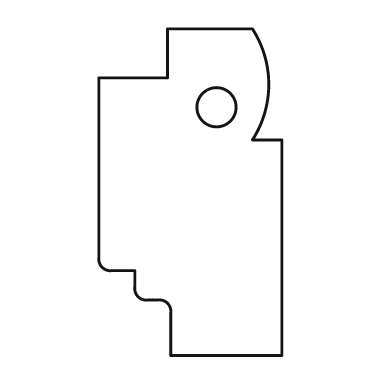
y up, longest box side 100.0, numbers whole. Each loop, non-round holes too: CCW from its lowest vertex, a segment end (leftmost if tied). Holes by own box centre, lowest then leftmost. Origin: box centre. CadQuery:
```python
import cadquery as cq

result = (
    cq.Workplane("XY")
    .moveTo(-6.0, -50.0)
    .lineTo(28.0, -50.0)
    .lineTo(28.0, 16.0)
    .lineTo(19.0, 16.0)
    .threePointArc((24.0, 33.0), (19.0, 50.0))
    .lineTo(-7.0, 50.0)
    .lineTo(-7.0, 35.0)
    .lineTo(-28.0, 35.0)
    .lineTo(-28.0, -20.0)
    .threePointArc((-27.0, -23.0), (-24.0, -24.0))
    .lineTo(-17.0, -24.0)
    .lineTo(-17.0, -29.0)
    .threePointArc((-16.0, -32.0), (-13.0, -33.0))
    .lineTo(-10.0, -33.0)
    .threePointArc((-7.0, -34.0), (-6.0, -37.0))
    .close()
    .moveTo(8.0, 26.0)
    .circle(6.0)
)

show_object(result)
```